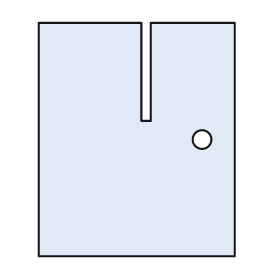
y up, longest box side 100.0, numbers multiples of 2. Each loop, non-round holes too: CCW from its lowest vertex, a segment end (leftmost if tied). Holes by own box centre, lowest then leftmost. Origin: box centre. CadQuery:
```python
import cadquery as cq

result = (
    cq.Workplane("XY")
    .moveTo(-42.0, -50.0)
    .lineTo(42.0, -50.0)
    .lineTo(42.0, 50.0)
    .lineTo(6.0, 50.0)
    .lineTo(6.0, 8.0)
    .lineTo(2.0, 8.0)
    .lineTo(2.0, 50.0)
    .lineTo(-42.0, 50.0)
    .close()
    .moveTo(28.0, 0.0)
    .circle(4.0)
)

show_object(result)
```